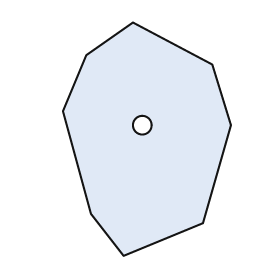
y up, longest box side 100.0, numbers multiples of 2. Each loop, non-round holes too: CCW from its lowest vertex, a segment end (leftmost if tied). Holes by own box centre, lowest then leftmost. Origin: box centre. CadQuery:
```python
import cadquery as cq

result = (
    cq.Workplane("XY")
    .moveTo(-10.0, -50.0)
    .lineTo(24.0, -36.0)
    .lineTo(36.0, 6.0)
    .lineTo(28.0, 32.0)
    .lineTo(-6.0, 50.0)
    .lineTo(-26.0, 36.0)
    .lineTo(-36.0, 12.0)
    .lineTo(-24.0, -32.0)
    .close()
    .moveTo(-2.0, 6.0)
    .circle(4.0)
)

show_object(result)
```